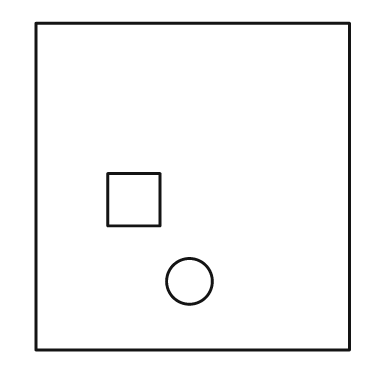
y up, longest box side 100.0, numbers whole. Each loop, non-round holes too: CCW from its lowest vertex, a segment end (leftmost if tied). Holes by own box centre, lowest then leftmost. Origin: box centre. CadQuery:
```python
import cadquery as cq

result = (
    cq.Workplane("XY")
    .moveTo(-48.0, -50.0)
    .lineTo(48.0, -50.0)
    .lineTo(48.0, 50.0)
    .lineTo(-48.0, 50.0)
    .close()
    .moveTo(-1.0, -29.0)
    .circle(7.0)
    .moveTo(-26.0, -12.0)
    .lineTo(-10.0, -12.0)
    .lineTo(-10.0, 4.0)
    .lineTo(-26.0, 4.0)
    .close()
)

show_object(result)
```